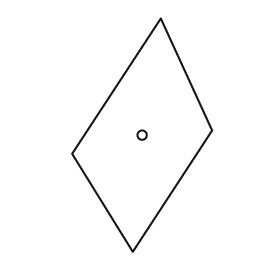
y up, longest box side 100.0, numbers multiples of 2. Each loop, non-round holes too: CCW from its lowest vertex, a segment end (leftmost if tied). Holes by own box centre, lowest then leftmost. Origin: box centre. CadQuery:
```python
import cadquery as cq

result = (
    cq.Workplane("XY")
    .moveTo(-4.0, -50.0)
    .lineTo(30.0, 2.0)
    .lineTo(8.0, 50.0)
    .lineTo(-30.0, -8.0)
    .close()
    .moveTo(0.0, 0.0)
    .circle(2.0)
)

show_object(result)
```